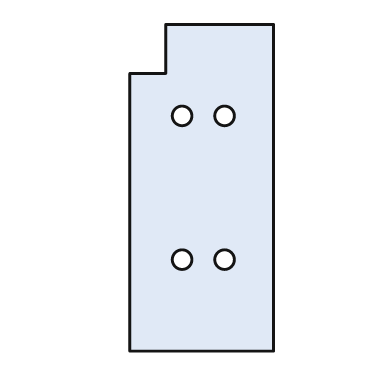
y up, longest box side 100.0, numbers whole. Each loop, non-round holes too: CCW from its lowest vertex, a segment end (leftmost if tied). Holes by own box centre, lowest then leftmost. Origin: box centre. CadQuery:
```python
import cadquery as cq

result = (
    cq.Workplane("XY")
    .moveTo(-22.0, -50.0)
    .lineTo(22.0, -50.0)
    .lineTo(22.0, 50.0)
    .lineTo(-11.0, 50.0)
    .lineTo(-11.0, 35.0)
    .lineTo(-22.0, 35.0)
    .close()
    .moveTo(-6.0, -22.0)
    .circle(3.0)
    .moveTo(7.0, -22.0)
    .circle(3.0)
    .moveTo(-6.0, 22.0)
    .circle(3.0)
    .moveTo(7.0, 22.0)
    .circle(3.0)
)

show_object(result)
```